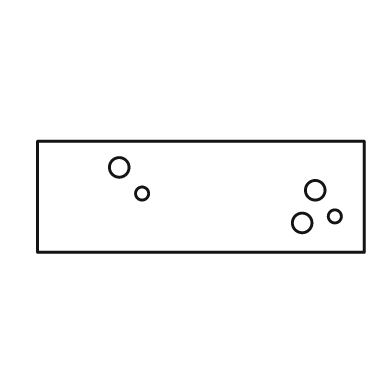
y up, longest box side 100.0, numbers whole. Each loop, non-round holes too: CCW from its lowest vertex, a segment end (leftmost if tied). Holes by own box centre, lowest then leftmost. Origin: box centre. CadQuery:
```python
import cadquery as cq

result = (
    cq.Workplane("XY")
    .moveTo(-50.0, -17.0)
    .lineTo(50.0, -17.0)
    .lineTo(50.0, 17.0)
    .lineTo(-50.0, 17.0)
    .close()
    .moveTo(31.0, -8.0)
    .circle(3.0)
    .moveTo(41.0, -6.0)
    .circle(2.0)
    .moveTo(-18.0, 1.0)
    .circle(2.0)
    .moveTo(35.0, 2.0)
    .circle(3.0)
    .moveTo(-25.0, 9.0)
    .circle(3.0)
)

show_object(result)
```